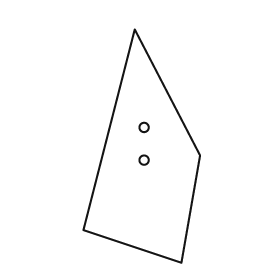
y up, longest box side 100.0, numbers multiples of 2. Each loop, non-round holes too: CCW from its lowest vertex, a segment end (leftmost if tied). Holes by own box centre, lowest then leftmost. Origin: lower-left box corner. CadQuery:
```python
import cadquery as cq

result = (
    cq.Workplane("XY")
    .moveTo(42.0, 0.0)
    .lineTo(50.0, 46.0)
    .lineTo(22.0, 100.0)
    .lineTo(0.0, 14.0)
    .close()
    .moveTo(26.0, 44.0)
    .circle(2.0)
    .moveTo(26.0, 58.0)
    .circle(2.0)
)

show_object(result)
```